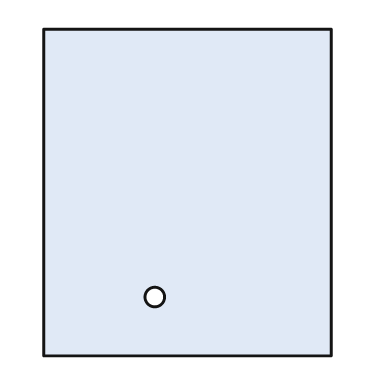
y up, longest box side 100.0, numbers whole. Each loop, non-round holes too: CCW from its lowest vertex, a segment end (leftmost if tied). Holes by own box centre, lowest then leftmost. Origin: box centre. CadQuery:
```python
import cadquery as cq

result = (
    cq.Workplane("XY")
    .moveTo(-44.0, -50.0)
    .lineTo(44.0, -50.0)
    .lineTo(44.0, 50.0)
    .lineTo(-44.0, 50.0)
    .close()
    .moveTo(-10.0, -32.0)
    .circle(3.0)
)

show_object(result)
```